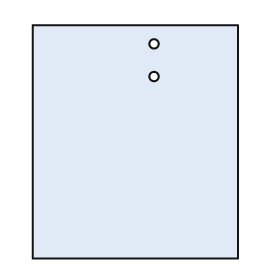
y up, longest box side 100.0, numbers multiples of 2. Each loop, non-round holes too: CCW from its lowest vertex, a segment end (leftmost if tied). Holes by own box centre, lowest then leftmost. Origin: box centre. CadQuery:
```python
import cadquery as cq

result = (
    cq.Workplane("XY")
    .moveTo(-44.0, -50.0)
    .lineTo(44.0, -50.0)
    .lineTo(44.0, 50.0)
    .lineTo(-44.0, 50.0)
    .close()
    .moveTo(8.0, 28.0)
    .circle(2.0)
    .moveTo(8.0, 42.0)
    .circle(2.0)
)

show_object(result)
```